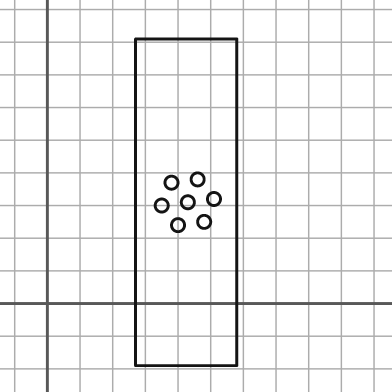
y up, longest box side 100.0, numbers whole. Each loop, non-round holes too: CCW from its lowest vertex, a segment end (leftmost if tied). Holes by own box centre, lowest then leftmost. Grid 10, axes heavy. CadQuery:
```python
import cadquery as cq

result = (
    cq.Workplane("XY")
    .moveTo(27.0, -19.0)
    .lineTo(58.0, -19.0)
    .lineTo(58.0, 81.0)
    .lineTo(27.0, 81.0)
    .close()
    .moveTo(40.0, 24.0)
    .circle(2.0)
    .moveTo(48.0, 25.0)
    .circle(2.0)
    .moveTo(35.0, 30.0)
    .circle(2.0)
    .moveTo(43.0, 31.0)
    .circle(2.0)
    .moveTo(51.0, 32.0)
    .circle(2.0)
    .moveTo(38.0, 37.0)
    .circle(2.0)
    .moveTo(46.0, 38.0)
    .circle(2.0)
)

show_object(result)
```